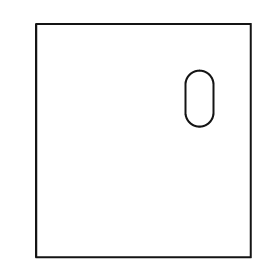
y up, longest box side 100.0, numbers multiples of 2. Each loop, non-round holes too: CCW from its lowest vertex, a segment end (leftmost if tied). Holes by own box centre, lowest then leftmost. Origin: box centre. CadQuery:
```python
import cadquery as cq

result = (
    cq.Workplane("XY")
    .moveTo(-46.0, -50.0)
    .lineTo(46.0, -50.0)
    .lineTo(46.0, 50.0)
    .lineTo(-46.0, 50.0)
    .close()
    .moveTo(18.0, 12.0)
    .threePointArc((24.0, 6.0), (30.0, 12.0))
    .lineTo(30.0, 24.0)
    .threePointArc((24.0, 30.0), (18.0, 24.0))
    .close()
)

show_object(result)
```